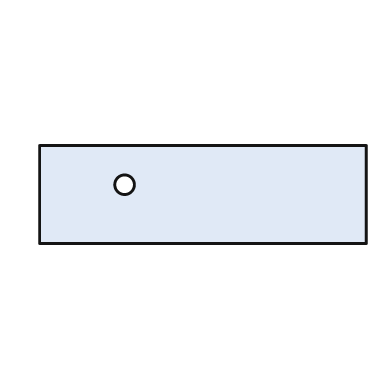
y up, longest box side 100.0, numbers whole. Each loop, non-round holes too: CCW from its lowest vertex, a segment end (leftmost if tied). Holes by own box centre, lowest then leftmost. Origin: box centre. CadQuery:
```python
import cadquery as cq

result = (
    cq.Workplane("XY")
    .moveTo(-50.0, -15.0)
    .lineTo(50.0, -15.0)
    .lineTo(50.0, 15.0)
    .lineTo(-50.0, 15.0)
    .close()
    .moveTo(-24.0, 3.0)
    .circle(3.0)
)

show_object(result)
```